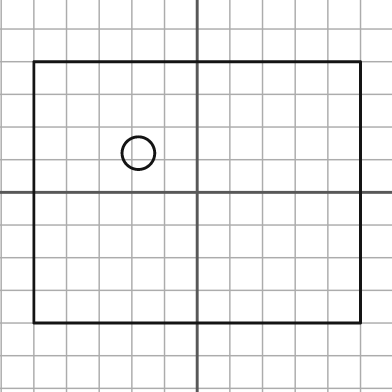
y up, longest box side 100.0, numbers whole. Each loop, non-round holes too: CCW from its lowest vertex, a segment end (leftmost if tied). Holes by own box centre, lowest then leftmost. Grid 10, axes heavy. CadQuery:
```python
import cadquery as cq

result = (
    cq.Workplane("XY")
    .moveTo(-50.0, -40.0)
    .lineTo(50.0, -40.0)
    .lineTo(50.0, 40.0)
    .lineTo(-50.0, 40.0)
    .close()
    .moveTo(-18.0, 12.0)
    .circle(5.0)
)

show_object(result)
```